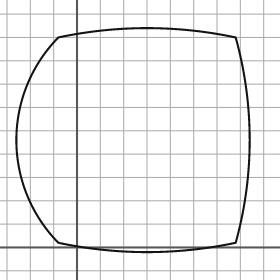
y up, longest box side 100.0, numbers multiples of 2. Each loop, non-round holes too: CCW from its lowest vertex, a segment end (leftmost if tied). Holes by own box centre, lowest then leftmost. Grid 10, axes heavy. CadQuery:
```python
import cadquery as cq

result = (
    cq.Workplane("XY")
    .moveTo(-8.0, 2.0)
    .threePointArc((30.0, -2.0), (68.0, 2.0))
    .threePointArc((74.0, 46.0), (68.0, 90.0))
    .threePointArc((30.0, 94.0), (-8.0, 90.0))
    .threePointArc((-26.0, 46.0), (-8.0, 2.0))
    .close()
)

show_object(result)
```